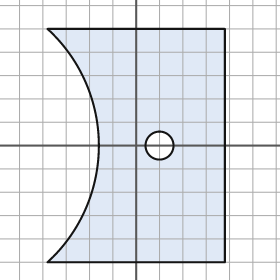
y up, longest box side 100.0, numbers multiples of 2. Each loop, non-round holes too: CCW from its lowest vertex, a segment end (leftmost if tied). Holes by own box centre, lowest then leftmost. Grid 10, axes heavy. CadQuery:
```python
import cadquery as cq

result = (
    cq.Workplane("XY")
    .moveTo(-38.0, -50.0)
    .lineTo(38.0, -50.0)
    .lineTo(38.0, 50.0)
    .lineTo(-38.0, 50.0)
    .threePointArc((-16.0, 0.0), (-38.0, -50.0))
    .close()
    .moveTo(10.0, 0.0)
    .circle(6.0)
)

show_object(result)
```